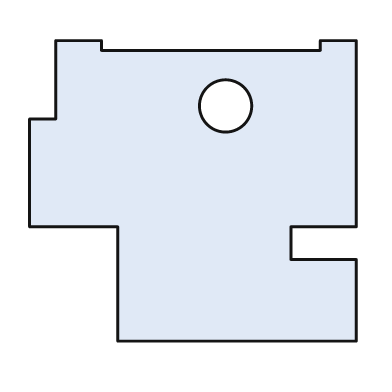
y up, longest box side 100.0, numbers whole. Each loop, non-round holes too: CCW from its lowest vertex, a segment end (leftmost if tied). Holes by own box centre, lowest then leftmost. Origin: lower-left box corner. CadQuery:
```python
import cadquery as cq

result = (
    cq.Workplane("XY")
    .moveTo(27.0, 0.0)
    .lineTo(100.0, 0.0)
    .lineTo(100.0, 25.0)
    .lineTo(80.0, 25.0)
    .lineTo(80.0, 35.0)
    .lineTo(100.0, 35.0)
    .lineTo(100.0, 92.0)
    .lineTo(89.0, 92.0)
    .lineTo(89.0, 89.0)
    .lineTo(22.0, 89.0)
    .lineTo(22.0, 92.0)
    .lineTo(8.0, 92.0)
    .lineTo(8.0, 68.0)
    .lineTo(0.0, 68.0)
    .lineTo(0.0, 35.0)
    .lineTo(27.0, 35.0)
    .close()
    .moveTo(60.0, 72.0)
    .circle(8.0)
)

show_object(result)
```